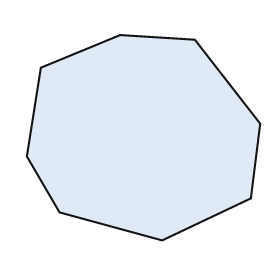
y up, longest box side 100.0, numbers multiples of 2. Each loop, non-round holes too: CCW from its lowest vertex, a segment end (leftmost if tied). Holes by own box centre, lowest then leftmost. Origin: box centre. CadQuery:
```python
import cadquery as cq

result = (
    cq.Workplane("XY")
    .moveTo(8.0, -44.0)
    .lineTo(46.0, -26.0)
    .lineTo(50.0, 6.0)
    .lineTo(22.0, 42.0)
    .lineTo(-10.0, 44.0)
    .lineTo(-44.0, 30.0)
    .lineTo(-50.0, -8.0)
    .lineTo(-36.0, -32.0)
    .close()
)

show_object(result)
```